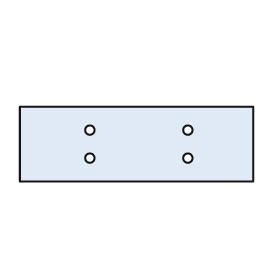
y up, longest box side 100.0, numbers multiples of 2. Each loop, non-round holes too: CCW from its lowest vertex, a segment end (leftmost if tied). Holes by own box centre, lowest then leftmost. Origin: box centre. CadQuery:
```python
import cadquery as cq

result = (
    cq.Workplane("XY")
    .moveTo(-50.0, -16.0)
    .lineTo(50.0, -16.0)
    .lineTo(50.0, 16.0)
    .lineTo(-50.0, 16.0)
    .close()
    .moveTo(-20.0, -6.0)
    .circle(2.0)
    .moveTo(22.0, -6.0)
    .circle(2.0)
    .moveTo(-20.0, 6.0)
    .circle(2.0)
    .moveTo(22.0, 6.0)
    .circle(2.0)
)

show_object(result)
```